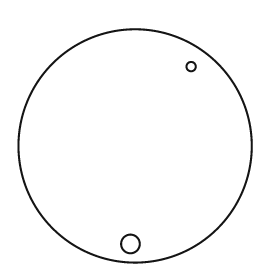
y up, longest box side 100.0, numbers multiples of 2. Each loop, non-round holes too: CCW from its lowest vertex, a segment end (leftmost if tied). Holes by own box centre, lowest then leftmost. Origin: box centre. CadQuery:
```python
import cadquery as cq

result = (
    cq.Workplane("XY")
    .moveTo(0.0, 0.0)
    .circle(50.0)
    .moveTo(-2.0, -42.0)
    .circle(4.0)
    .moveTo(24.0, 34.0)
    .circle(2.0)
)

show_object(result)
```